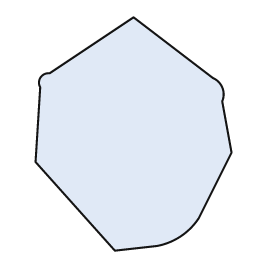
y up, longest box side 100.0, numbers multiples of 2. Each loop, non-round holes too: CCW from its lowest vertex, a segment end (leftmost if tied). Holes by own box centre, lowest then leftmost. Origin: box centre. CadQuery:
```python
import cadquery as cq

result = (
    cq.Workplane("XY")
    .moveTo(-8.0, -50.0)
    .lineTo(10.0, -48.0)
    .threePointArc((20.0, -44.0), (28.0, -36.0))
    .lineTo(42.0, -8.0)
    .lineTo(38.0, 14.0)
    .threePointArc((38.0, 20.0), (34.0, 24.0))
    .lineTo(0.0, 50.0)
    .lineTo(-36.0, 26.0)
    .threePointArc((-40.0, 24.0), (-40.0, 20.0))
    .lineTo(-42.0, -12.0)
    .close()
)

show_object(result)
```